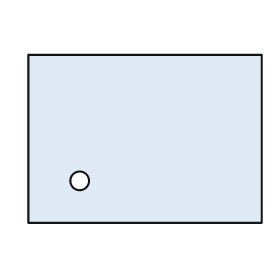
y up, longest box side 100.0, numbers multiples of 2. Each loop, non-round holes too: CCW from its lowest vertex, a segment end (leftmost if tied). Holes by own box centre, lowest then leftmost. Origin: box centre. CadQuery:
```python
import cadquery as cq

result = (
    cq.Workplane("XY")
    .moveTo(-50.0, -36.0)
    .lineTo(50.0, -36.0)
    .lineTo(50.0, 36.0)
    .lineTo(-50.0, 36.0)
    .close()
    .moveTo(-28.0, -18.0)
    .circle(4.0)
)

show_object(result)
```